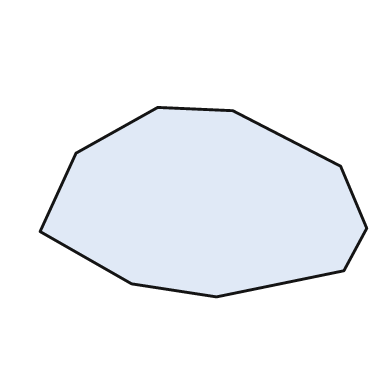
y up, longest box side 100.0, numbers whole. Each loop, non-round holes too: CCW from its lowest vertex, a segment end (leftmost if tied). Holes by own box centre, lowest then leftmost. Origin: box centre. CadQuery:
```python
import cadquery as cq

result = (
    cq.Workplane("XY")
    .moveTo(4.0, -29.0)
    .lineTo(43.0, -21.0)
    .lineTo(50.0, -8.0)
    .lineTo(42.0, 11.0)
    .lineTo(9.0, 28.0)
    .lineTo(-14.0, 29.0)
    .lineTo(-39.0, 15.0)
    .lineTo(-50.0, -9.0)
    .lineTo(-22.0, -25.0)
    .close()
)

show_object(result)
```